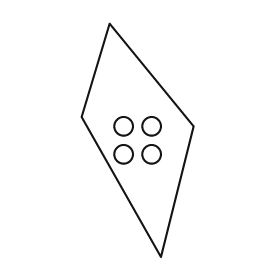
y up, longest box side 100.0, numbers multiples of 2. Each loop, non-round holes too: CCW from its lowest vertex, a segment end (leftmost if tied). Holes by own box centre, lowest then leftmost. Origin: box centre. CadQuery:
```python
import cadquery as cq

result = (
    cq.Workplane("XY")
    .moveTo(10.0, -50.0)
    .lineTo(24.0, 6.0)
    .lineTo(-12.0, 50.0)
    .lineTo(-24.0, 10.0)
    .close()
    .moveTo(-6.0, -6.0)
    .circle(4.0)
    .moveTo(6.0, -6.0)
    .circle(4.0)
    .moveTo(-6.0, 6.0)
    .circle(4.0)
    .moveTo(6.0, 6.0)
    .circle(4.0)
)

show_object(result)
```